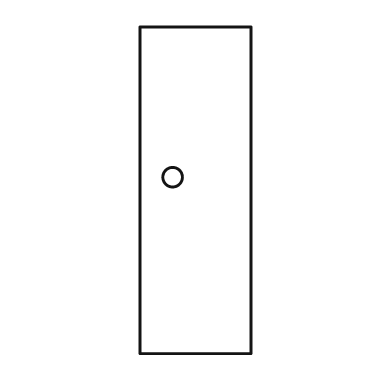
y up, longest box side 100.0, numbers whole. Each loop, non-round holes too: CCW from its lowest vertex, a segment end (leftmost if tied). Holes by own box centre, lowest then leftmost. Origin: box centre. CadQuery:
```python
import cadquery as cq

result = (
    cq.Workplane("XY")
    .moveTo(-17.0, -50.0)
    .lineTo(17.0, -50.0)
    .lineTo(17.0, 50.0)
    .lineTo(-17.0, 50.0)
    .close()
    .moveTo(-7.0, 4.0)
    .circle(3.0)
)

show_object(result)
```